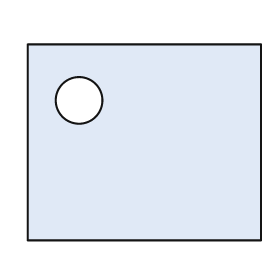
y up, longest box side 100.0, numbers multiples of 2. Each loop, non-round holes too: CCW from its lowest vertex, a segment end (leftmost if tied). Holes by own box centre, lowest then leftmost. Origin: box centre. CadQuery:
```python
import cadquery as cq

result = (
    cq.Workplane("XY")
    .moveTo(-50.0, -42.0)
    .lineTo(50.0, -42.0)
    .lineTo(50.0, 42.0)
    .lineTo(-50.0, 42.0)
    .close()
    .moveTo(-28.0, 18.0)
    .circle(10.0)
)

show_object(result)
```